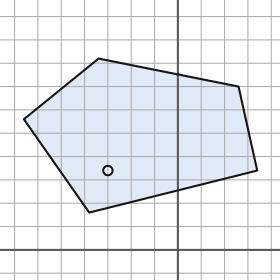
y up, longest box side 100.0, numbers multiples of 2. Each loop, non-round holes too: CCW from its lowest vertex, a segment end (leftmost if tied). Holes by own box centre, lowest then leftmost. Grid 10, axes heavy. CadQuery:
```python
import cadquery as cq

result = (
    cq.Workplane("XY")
    .moveTo(-38.0, 16.0)
    .lineTo(34.0, 34.0)
    .lineTo(26.0, 70.0)
    .lineTo(-34.0, 82.0)
    .lineTo(-66.0, 56.0)
    .close()
    .moveTo(-30.0, 34.0)
    .circle(2.0)
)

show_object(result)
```